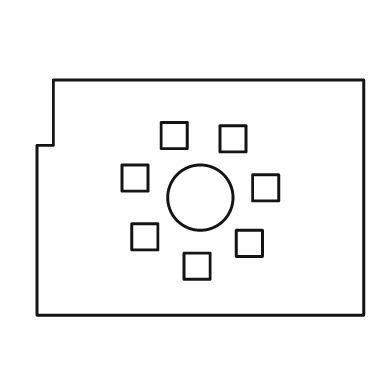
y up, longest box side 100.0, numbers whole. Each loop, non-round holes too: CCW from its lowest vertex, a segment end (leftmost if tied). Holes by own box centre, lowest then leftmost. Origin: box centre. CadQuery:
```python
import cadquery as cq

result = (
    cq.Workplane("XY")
    .moveTo(-50.0, -36.0)
    .lineTo(50.0, -36.0)
    .lineTo(50.0, 36.0)
    .lineTo(-45.0, 36.0)
    .lineTo(-45.0, 16.0)
    .lineTo(-50.0, 16.0)
    .close()
    .moveTo(-5.0, -25.0)
    .lineTo(3.0, -25.0)
    .lineTo(3.0, -17.0)
    .lineTo(-5.0, -17.0)
    .close()
    .moveTo(11.0, -18.0)
    .lineTo(19.0, -18.0)
    .lineTo(19.0, -10.0)
    .lineTo(11.0, -10.0)
    .close()
    .moveTo(-21.0, -16.0)
    .lineTo(-13.0, -16.0)
    .lineTo(-13.0, -8.0)
    .lineTo(-21.0, -8.0)
    .close()
    .moveTo(0.0, 0.0)
    .circle(10.0)
    .moveTo(16.0, -1.0)
    .lineTo(24.0, -1.0)
    .lineTo(24.0, 7.0)
    .lineTo(16.0, 7.0)
    .close()
    .moveTo(-24.0, 2.0)
    .lineTo(-16.0, 2.0)
    .lineTo(-16.0, 10.0)
    .lineTo(-24.0, 10.0)
    .close()
    .moveTo(6.0, 14.0)
    .lineTo(14.0, 14.0)
    .lineTo(14.0, 22.0)
    .lineTo(6.0, 22.0)
    .close()
    .moveTo(-12.0, 15.0)
    .lineTo(-4.0, 15.0)
    .lineTo(-4.0, 23.0)
    .lineTo(-12.0, 23.0)
    .close()
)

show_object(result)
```